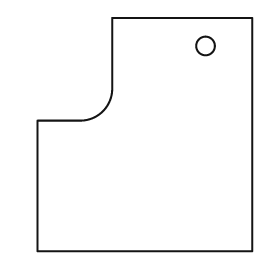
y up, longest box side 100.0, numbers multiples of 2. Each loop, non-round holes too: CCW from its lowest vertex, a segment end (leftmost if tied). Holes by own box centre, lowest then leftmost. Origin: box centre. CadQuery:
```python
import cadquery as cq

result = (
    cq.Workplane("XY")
    .moveTo(-46.0, -50.0)
    .lineTo(46.0, -50.0)
    .lineTo(46.0, 50.0)
    .lineTo(-14.0, 50.0)
    .lineTo(-14.0, 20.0)
    .threePointArc((-18.0, 10.0), (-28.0, 6.0))
    .lineTo(-46.0, 6.0)
    .close()
    .moveTo(26.0, 38.0)
    .circle(4.0)
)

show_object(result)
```